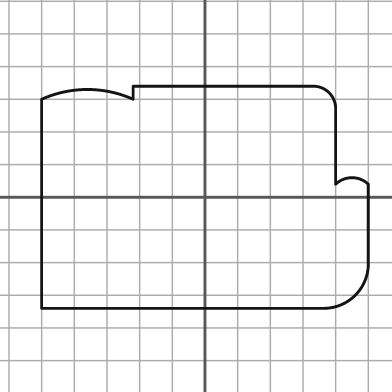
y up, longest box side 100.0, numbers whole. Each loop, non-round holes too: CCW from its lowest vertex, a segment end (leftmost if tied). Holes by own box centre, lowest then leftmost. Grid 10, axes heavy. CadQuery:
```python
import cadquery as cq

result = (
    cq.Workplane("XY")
    .moveTo(-50.0, -34.0)
    .lineTo(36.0, -34.0)
    .threePointArc((46.0, -30.0), (50.0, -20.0))
    .lineTo(50.0, 4.0)
    .threePointArc((45.0, 6.0), (40.0, 4.0))
    .lineTo(40.0, 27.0)
    .threePointArc((38.0, 32.0), (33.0, 34.0))
    .lineTo(-22.0, 34.0)
    .lineTo(-22.0, 30.0)
    .threePointArc((-36.0, 33.0), (-50.0, 30.0))
    .close()
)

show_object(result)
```